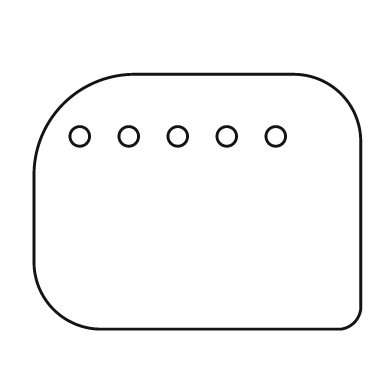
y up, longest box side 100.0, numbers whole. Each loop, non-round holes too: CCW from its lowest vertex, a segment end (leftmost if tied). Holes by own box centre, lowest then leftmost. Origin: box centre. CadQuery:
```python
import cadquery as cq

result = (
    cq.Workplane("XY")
    .moveTo(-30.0, -39.0)
    .lineTo(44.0, -39.0)
    .threePointArc((48.0, -37.0), (50.0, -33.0))
    .lineTo(50.0, 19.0)
    .threePointArc((44.0, 33.0), (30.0, 39.0))
    .lineTo(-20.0, 39.0)
    .threePointArc((-41.0, 30.0), (-50.0, 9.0))
    .lineTo(-50.0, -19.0)
    .threePointArc((-44.0, -33.0), (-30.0, -39.0))
    .close()
    .moveTo(-36.0, 20.0)
    .circle(3.0)
    .moveTo(-21.0, 20.0)
    .circle(3.0)
    .moveTo(-6.0, 20.0)
    .circle(3.0)
    .moveTo(9.0, 20.0)
    .circle(3.0)
    .moveTo(24.0, 20.0)
    .circle(3.0)
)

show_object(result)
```